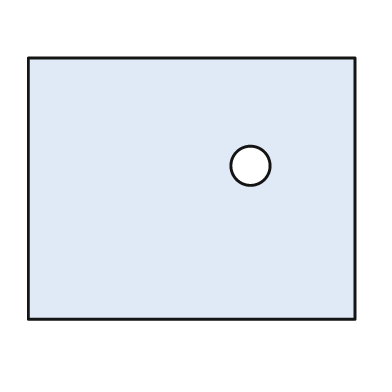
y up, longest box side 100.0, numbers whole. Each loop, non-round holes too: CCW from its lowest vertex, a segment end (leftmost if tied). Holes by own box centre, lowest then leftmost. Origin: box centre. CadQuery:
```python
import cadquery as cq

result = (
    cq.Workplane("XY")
    .moveTo(-50.0, -40.0)
    .lineTo(50.0, -40.0)
    .lineTo(50.0, 40.0)
    .lineTo(-50.0, 40.0)
    .close()
    .moveTo(18.0, 7.0)
    .circle(6.0)
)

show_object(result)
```